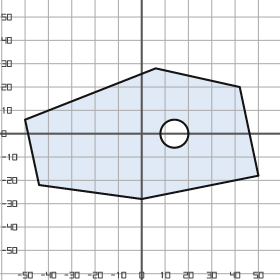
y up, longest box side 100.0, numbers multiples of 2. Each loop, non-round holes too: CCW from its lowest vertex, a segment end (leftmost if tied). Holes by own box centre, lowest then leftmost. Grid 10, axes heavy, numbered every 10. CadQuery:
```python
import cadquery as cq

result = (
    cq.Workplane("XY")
    .moveTo(0.0, -28.0)
    .lineTo(50.0, -18.0)
    .lineTo(42.0, 20.0)
    .lineTo(6.0, 28.0)
    .lineTo(-50.0, 6.0)
    .lineTo(-44.0, -22.0)
    .close()
    .moveTo(14.0, 0.0)
    .circle(6.0)
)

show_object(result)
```